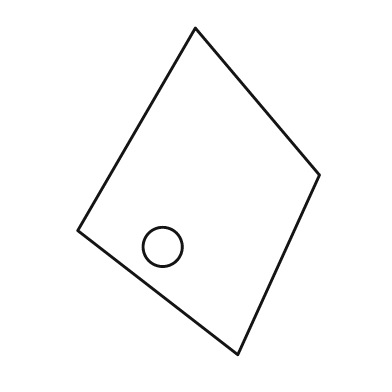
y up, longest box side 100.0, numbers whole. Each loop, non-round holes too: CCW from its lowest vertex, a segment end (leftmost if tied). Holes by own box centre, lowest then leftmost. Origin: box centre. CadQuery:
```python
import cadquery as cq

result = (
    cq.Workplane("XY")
    .moveTo(12.0, -50.0)
    .lineTo(37.0, 5.0)
    .lineTo(-1.0, 50.0)
    .lineTo(-37.0, -12.0)
    .close()
    .moveTo(-11.0, -17.0)
    .circle(6.0)
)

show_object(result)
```